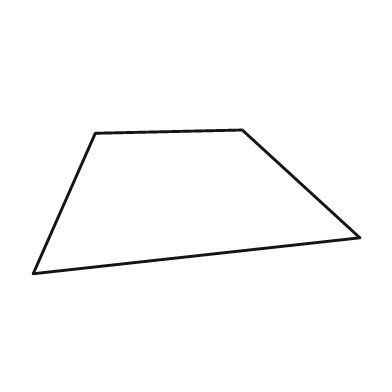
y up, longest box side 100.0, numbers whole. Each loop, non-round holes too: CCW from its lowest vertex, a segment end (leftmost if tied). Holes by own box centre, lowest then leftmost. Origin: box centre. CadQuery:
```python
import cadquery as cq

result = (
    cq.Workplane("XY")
    .moveTo(-50.0, -22.0)
    .lineTo(50.0, -11.0)
    .lineTo(14.0, 22.0)
    .lineTo(-31.0, 21.0)
    .close()
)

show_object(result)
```